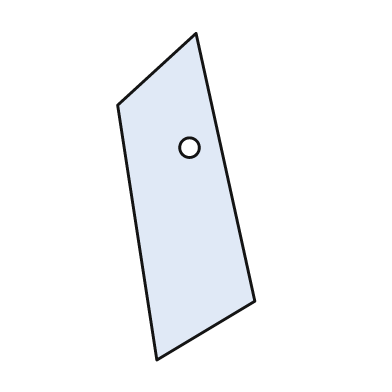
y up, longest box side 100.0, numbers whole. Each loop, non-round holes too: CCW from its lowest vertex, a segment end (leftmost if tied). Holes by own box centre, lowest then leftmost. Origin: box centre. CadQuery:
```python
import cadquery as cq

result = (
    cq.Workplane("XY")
    .moveTo(-9.0, -50.0)
    .lineTo(21.0, -32.0)
    .lineTo(3.0, 50.0)
    .lineTo(-21.0, 28.0)
    .close()
    .moveTo(1.0, 15.0)
    .circle(3.0)
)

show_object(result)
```